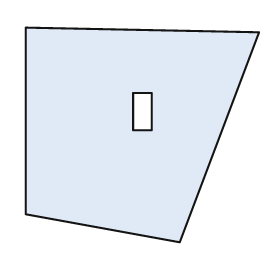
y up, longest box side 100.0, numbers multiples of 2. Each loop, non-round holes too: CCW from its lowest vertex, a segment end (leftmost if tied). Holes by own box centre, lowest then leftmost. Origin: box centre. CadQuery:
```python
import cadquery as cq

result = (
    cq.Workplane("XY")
    .moveTo(16.0, -46.0)
    .lineTo(50.0, 44.0)
    .lineTo(-50.0, 46.0)
    .lineTo(-50.0, -34.0)
    .close()
    .moveTo(-4.0, 2.0)
    .lineTo(4.0, 2.0)
    .lineTo(4.0, 18.0)
    .lineTo(-4.0, 18.0)
    .close()
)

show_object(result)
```